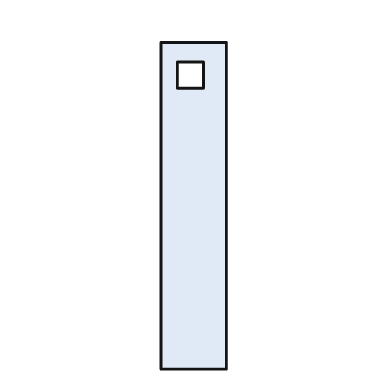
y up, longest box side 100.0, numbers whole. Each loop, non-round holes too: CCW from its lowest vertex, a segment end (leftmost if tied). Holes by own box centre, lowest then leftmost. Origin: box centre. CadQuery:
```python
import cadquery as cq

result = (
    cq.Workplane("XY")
    .moveTo(-10.0, -50.0)
    .lineTo(10.0, -50.0)
    .lineTo(10.0, 50.0)
    .lineTo(-10.0, 50.0)
    .close()
    .moveTo(-5.0, 36.0)
    .lineTo(3.0, 36.0)
    .lineTo(3.0, 44.0)
    .lineTo(-5.0, 44.0)
    .close()
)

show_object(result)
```